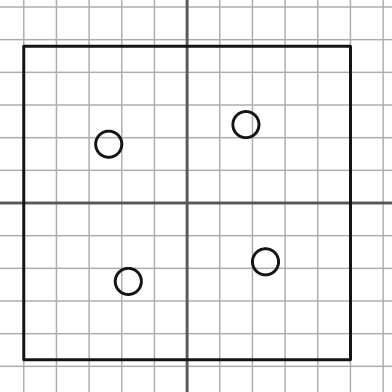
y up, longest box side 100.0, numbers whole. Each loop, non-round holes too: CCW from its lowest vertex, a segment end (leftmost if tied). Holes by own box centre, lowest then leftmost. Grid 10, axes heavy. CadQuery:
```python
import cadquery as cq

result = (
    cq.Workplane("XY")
    .moveTo(-50.0, -48.0)
    .lineTo(50.0, -48.0)
    .lineTo(50.0, 48.0)
    .lineTo(-50.0, 48.0)
    .close()
    .moveTo(-18.0, -24.0)
    .circle(4.0)
    .moveTo(24.0, -18.0)
    .circle(4.0)
    .moveTo(-24.0, 18.0)
    .circle(4.0)
    .moveTo(18.0, 24.0)
    .circle(4.0)
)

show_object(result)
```